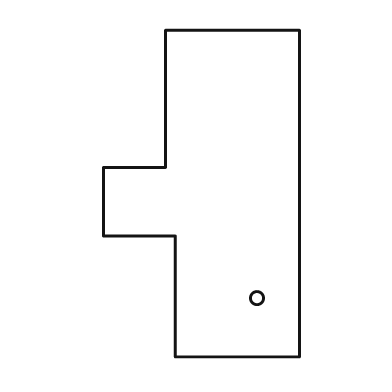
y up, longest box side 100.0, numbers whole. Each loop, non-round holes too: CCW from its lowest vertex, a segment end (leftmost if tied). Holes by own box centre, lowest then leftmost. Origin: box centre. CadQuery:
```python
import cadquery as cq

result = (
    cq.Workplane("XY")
    .moveTo(-8.0, -50.0)
    .lineTo(30.0, -50.0)
    .lineTo(30.0, 50.0)
    .lineTo(-11.0, 50.0)
    .lineTo(-11.0, 8.0)
    .lineTo(-30.0, 8.0)
    .lineTo(-30.0, -13.0)
    .lineTo(-8.0, -13.0)
    .close()
    .moveTo(17.0, -32.0)
    .circle(2.0)
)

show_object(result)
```